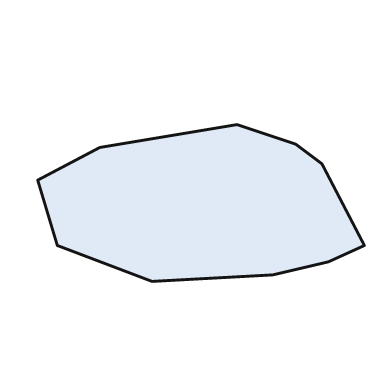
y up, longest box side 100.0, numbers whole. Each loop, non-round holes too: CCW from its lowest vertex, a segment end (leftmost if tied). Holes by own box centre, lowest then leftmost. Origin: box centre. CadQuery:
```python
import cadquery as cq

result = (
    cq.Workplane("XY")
    .moveTo(-15.0, -24.0)
    .lineTo(22.0, -22.0)
    .lineTo(39.0, -18.0)
    .lineTo(50.0, -13.0)
    .lineTo(37.0, 12.0)
    .lineTo(29.0, 18.0)
    .lineTo(11.0, 24.0)
    .lineTo(-31.0, 17.0)
    .lineTo(-50.0, 7.0)
    .lineTo(-44.0, -13.0)
    .close()
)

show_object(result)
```